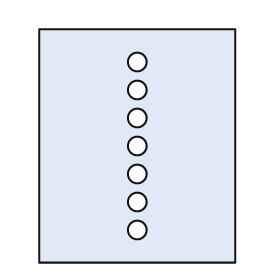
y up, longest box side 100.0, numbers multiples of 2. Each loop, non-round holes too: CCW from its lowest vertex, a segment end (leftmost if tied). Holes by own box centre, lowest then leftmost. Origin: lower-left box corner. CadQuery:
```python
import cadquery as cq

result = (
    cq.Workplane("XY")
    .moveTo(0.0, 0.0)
    .lineTo(84.0, 0.0)
    .lineTo(84.0, 100.0)
    .lineTo(0.0, 100.0)
    .close()
    .moveTo(42.0, 14.0)
    .circle(4.0)
    .moveTo(42.0, 26.0)
    .circle(4.0)
    .moveTo(42.0, 38.0)
    .circle(4.0)
    .moveTo(42.0, 50.0)
    .circle(4.0)
    .moveTo(42.0, 62.0)
    .circle(4.0)
    .moveTo(42.0, 74.0)
    .circle(4.0)
    .moveTo(42.0, 86.0)
    .circle(4.0)
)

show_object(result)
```